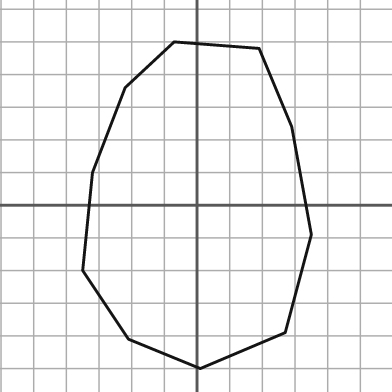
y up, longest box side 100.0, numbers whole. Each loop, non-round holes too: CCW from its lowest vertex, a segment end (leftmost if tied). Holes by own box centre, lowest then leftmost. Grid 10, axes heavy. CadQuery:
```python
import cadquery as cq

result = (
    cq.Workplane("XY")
    .moveTo(1.0, -50.0)
    .lineTo(27.0, -39.0)
    .lineTo(35.0, -9.0)
    .lineTo(29.0, 24.0)
    .lineTo(19.0, 48.0)
    .lineTo(-7.0, 50.0)
    .lineTo(-22.0, 36.0)
    .lineTo(-32.0, 10.0)
    .lineTo(-35.0, -20.0)
    .lineTo(-21.0, -41.0)
    .close()
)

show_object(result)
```